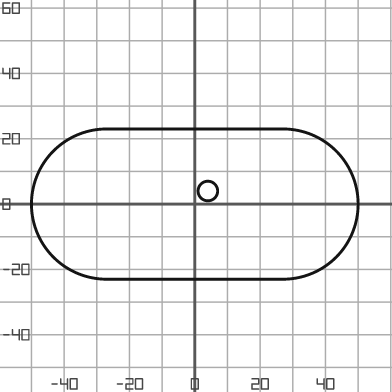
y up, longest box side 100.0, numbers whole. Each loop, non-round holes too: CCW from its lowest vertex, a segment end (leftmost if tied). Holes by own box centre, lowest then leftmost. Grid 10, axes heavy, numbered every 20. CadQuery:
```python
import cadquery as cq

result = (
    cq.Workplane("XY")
    .moveTo(-27.0, -23.0)
    .lineTo(27.0, -23.0)
    .threePointArc((50.0, 0.0), (27.0, 23.0))
    .lineTo(-27.0, 23.0)
    .threePointArc((-50.0, 0.0), (-27.0, -23.0))
    .close()
    .moveTo(4.0, 4.0)
    .circle(3.0)
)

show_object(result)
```